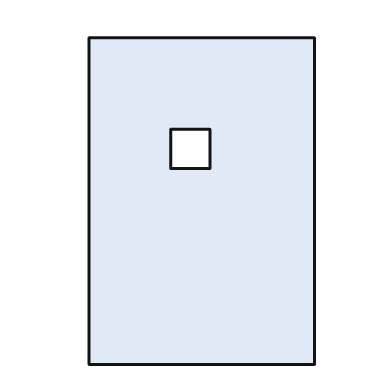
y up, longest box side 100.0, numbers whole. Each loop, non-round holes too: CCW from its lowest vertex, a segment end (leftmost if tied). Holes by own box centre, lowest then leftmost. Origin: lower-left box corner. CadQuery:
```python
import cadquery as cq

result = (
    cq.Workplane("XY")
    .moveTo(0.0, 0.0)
    .lineTo(69.0, 0.0)
    .lineTo(69.0, 100.0)
    .lineTo(0.0, 100.0)
    .close()
    .moveTo(25.0, 60.0)
    .lineTo(37.0, 60.0)
    .lineTo(37.0, 72.0)
    .lineTo(25.0, 72.0)
    .close()
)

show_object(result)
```